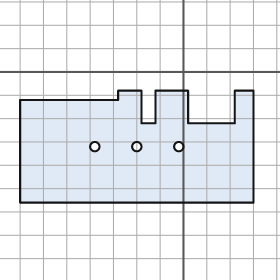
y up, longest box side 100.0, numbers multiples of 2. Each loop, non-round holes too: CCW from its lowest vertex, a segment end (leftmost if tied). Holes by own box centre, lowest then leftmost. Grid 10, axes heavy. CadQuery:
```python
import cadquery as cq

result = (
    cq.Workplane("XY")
    .moveTo(-70.0, -56.0)
    .lineTo(30.0, -56.0)
    .lineTo(30.0, -8.0)
    .lineTo(22.0, -8.0)
    .lineTo(22.0, -22.0)
    .lineTo(2.0, -22.0)
    .lineTo(2.0, -8.0)
    .lineTo(-12.0, -8.0)
    .lineTo(-12.0, -22.0)
    .lineTo(-18.0, -22.0)
    .lineTo(-18.0, -8.0)
    .lineTo(-28.0, -8.0)
    .lineTo(-28.0, -12.0)
    .lineTo(-70.0, -12.0)
    .close()
    .moveTo(-38.0, -32.0)
    .circle(2.0)
    .moveTo(-20.0, -32.0)
    .circle(2.0)
    .moveTo(-2.0, -32.0)
    .circle(2.0)
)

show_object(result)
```